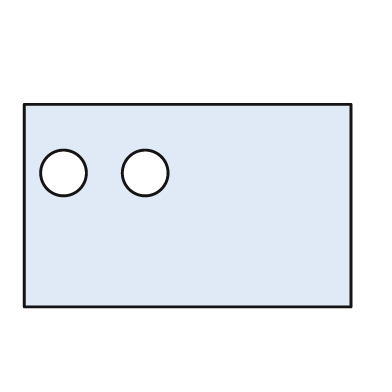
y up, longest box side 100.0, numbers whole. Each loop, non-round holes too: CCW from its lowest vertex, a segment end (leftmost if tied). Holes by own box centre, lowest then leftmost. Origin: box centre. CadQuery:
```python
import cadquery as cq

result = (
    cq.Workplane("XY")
    .moveTo(-50.0, -31.0)
    .lineTo(50.0, -31.0)
    .lineTo(50.0, 31.0)
    .lineTo(-50.0, 31.0)
    .close()
    .moveTo(-38.0, 10.0)
    .circle(7.0)
    .moveTo(-13.0, 10.0)
    .circle(7.0)
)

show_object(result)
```